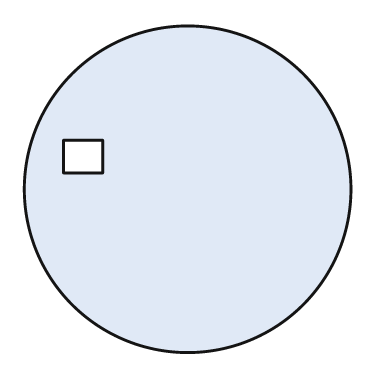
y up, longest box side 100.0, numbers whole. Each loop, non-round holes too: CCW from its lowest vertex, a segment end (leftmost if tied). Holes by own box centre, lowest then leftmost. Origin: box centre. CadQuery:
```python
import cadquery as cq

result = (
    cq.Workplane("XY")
    .moveTo(0.0, 0.0)
    .circle(50.0)
    .moveTo(-38.0, 5.0)
    .lineTo(-26.0, 5.0)
    .lineTo(-26.0, 15.0)
    .lineTo(-38.0, 15.0)
    .close()
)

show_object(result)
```